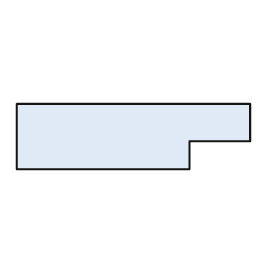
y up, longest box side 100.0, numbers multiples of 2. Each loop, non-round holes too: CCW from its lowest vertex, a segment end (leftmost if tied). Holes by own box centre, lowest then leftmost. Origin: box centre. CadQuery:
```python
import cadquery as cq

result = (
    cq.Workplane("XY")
    .moveTo(-50.0, -14.0)
    .lineTo(24.0, -14.0)
    .lineTo(24.0, -2.0)
    .lineTo(50.0, -2.0)
    .lineTo(50.0, 14.0)
    .lineTo(-50.0, 14.0)
    .close()
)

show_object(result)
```